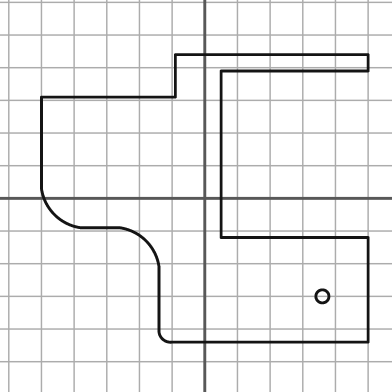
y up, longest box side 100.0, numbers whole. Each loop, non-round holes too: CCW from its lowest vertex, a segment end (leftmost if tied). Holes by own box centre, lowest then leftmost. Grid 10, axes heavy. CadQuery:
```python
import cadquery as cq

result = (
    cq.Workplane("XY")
    .moveTo(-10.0, -44.0)
    .lineTo(50.0, -44.0)
    .lineTo(50.0, -12.0)
    .lineTo(5.0, -12.0)
    .lineTo(5.0, 39.0)
    .lineTo(50.0, 39.0)
    .lineTo(50.0, 44.0)
    .lineTo(-9.0, 44.0)
    .lineTo(-9.0, 31.0)
    .lineTo(-50.0, 31.0)
    .lineTo(-50.0, 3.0)
    .threePointArc((-46.0, -5.0), (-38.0, -9.0))
    .lineTo(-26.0, -9.0)
    .threePointArc((-18.0, -13.0), (-14.0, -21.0))
    .lineTo(-14.0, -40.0)
    .threePointArc((-13.0, -43.0), (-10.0, -44.0))
    .close()
    .moveTo(36.0, -30.0)
    .circle(2.0)
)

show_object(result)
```